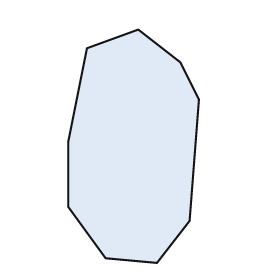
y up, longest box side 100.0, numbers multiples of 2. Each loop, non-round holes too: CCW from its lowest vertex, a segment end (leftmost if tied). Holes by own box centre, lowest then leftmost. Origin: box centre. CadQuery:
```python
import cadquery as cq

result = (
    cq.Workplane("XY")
    .moveTo(10.0, -50.0)
    .lineTo(24.0, -32.0)
    .lineTo(28.0, 20.0)
    .lineTo(20.0, 36.0)
    .lineTo(2.0, 50.0)
    .lineTo(-20.0, 42.0)
    .lineTo(-28.0, 2.0)
    .lineTo(-28.0, -26.0)
    .lineTo(-12.0, -48.0)
    .close()
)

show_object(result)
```